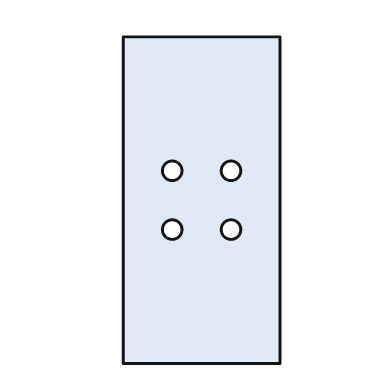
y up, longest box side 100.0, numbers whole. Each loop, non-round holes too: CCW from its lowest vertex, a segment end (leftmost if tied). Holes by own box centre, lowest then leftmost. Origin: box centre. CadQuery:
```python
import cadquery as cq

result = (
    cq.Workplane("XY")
    .moveTo(-24.0, -50.0)
    .lineTo(24.0, -50.0)
    .lineTo(24.0, 50.0)
    .lineTo(-24.0, 50.0)
    .close()
    .moveTo(-9.0, -9.0)
    .circle(3.0)
    .moveTo(9.0, -9.0)
    .circle(3.0)
    .moveTo(-9.0, 9.0)
    .circle(3.0)
    .moveTo(9.0, 9.0)
    .circle(3.0)
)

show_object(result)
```